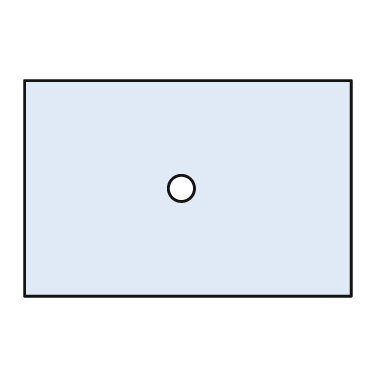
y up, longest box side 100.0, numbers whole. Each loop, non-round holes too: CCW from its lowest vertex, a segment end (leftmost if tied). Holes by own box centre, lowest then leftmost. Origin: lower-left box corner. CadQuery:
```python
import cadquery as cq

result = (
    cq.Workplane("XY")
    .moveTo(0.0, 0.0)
    .lineTo(100.0, 0.0)
    .lineTo(100.0, 66.0)
    .lineTo(0.0, 66.0)
    .close()
    .moveTo(48.0, 33.0)
    .circle(4.0)
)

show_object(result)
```